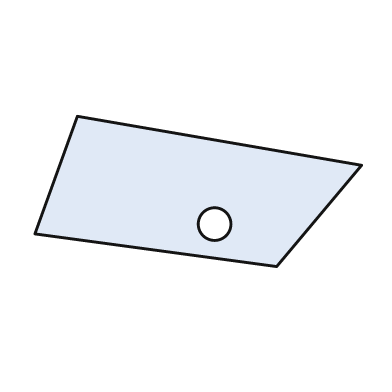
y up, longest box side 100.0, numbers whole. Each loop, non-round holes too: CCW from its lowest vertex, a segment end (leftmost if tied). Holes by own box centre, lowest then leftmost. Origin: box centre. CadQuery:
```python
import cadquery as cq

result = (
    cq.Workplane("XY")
    .moveTo(24.0, -23.0)
    .lineTo(50.0, 8.0)
    .lineTo(-37.0, 23.0)
    .lineTo(-50.0, -13.0)
    .close()
    .moveTo(5.0, -10.0)
    .circle(5.0)
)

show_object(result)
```